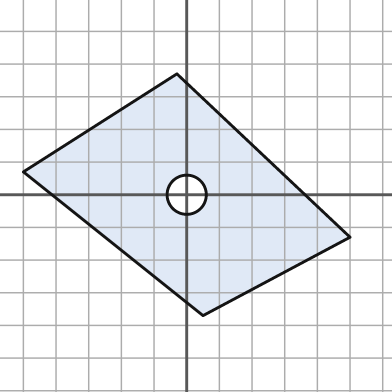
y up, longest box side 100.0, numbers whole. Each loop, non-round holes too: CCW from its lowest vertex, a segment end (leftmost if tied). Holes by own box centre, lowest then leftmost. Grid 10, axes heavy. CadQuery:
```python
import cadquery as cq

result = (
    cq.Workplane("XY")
    .moveTo(5.0, -37.0)
    .lineTo(50.0, -13.0)
    .lineTo(-3.0, 37.0)
    .lineTo(-50.0, 7.0)
    .close()
    .moveTo(0.0, 0.0)
    .circle(6.0)
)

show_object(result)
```